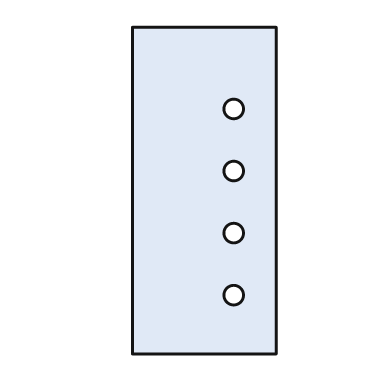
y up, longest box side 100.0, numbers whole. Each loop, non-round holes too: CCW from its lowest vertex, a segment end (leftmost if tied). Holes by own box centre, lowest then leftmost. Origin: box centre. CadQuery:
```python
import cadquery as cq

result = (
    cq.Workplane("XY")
    .moveTo(-22.0, -50.0)
    .lineTo(22.0, -50.0)
    .lineTo(22.0, 50.0)
    .lineTo(-22.0, 50.0)
    .close()
    .moveTo(9.0, -32.0)
    .circle(3.0)
    .moveTo(9.0, -13.0)
    .circle(3.0)
    .moveTo(9.0, 6.0)
    .circle(3.0)
    .moveTo(9.0, 25.0)
    .circle(3.0)
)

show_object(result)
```